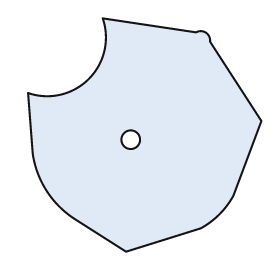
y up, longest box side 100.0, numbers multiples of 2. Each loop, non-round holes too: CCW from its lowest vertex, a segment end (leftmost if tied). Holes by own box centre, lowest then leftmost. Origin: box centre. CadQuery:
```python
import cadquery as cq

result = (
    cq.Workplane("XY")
    .moveTo(-8.0, -50.0)
    .lineTo(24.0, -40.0)
    .threePointArc((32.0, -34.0), (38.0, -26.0))
    .lineTo(50.0, 6.0)
    .lineTo(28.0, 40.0)
    .threePointArc((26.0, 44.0), (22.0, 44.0))
    .lineTo(-18.0, 50.0)
    .threePointArc((-24.0, 24.0), (-50.0, 18.0))
    .lineTo(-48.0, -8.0)
    .threePointArc((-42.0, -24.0), (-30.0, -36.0))
    .close()
    .moveTo(-6.0, -2.0)
    .circle(4.0)
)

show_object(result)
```